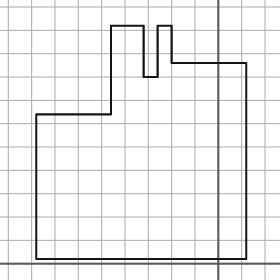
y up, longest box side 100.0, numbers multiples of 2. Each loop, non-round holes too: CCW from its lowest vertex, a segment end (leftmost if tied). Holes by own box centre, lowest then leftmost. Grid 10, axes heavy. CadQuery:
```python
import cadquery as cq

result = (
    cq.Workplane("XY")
    .moveTo(-78.0, 2.0)
    .lineTo(12.0, 2.0)
    .lineTo(12.0, 86.0)
    .lineTo(-20.0, 86.0)
    .lineTo(-20.0, 102.0)
    .lineTo(-26.0, 102.0)
    .lineTo(-26.0, 80.0)
    .lineTo(-32.0, 80.0)
    .lineTo(-32.0, 102.0)
    .lineTo(-46.0, 102.0)
    .lineTo(-46.0, 64.0)
    .lineTo(-78.0, 64.0)
    .close()
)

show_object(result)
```